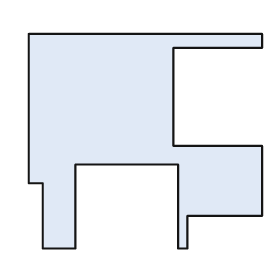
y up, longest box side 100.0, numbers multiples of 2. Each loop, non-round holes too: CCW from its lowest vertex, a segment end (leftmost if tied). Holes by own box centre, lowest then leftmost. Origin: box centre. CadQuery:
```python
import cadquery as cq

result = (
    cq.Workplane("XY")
    .moveTo(-44.0, -46.0)
    .lineTo(-30.0, -46.0)
    .lineTo(-30.0, -10.0)
    .lineTo(14.0, -10.0)
    .lineTo(14.0, -46.0)
    .lineTo(18.0, -46.0)
    .lineTo(18.0, -32.0)
    .lineTo(50.0, -32.0)
    .lineTo(50.0, -2.0)
    .lineTo(12.0, -2.0)
    .lineTo(12.0, 40.0)
    .lineTo(50.0, 40.0)
    .lineTo(50.0, 46.0)
    .lineTo(-50.0, 46.0)
    .lineTo(-50.0, -18.0)
    .lineTo(-44.0, -18.0)
    .close()
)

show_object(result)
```